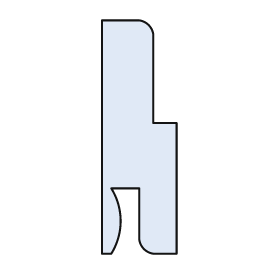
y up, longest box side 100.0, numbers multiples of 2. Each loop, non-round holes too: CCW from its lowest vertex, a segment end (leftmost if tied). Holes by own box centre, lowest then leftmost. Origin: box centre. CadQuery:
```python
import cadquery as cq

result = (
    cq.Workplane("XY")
    .moveTo(-16.0, -50.0)
    .lineTo(-12.0, -50.0)
    .threePointArc((-8.0, -36.0), (-12.0, -22.0))
    .lineTo(0.0, -22.0)
    .lineTo(0.0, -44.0)
    .threePointArc((2.0, -48.0), (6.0, -50.0))
    .lineTo(16.0, -50.0)
    .lineTo(16.0, 6.0)
    .lineTo(6.0, 6.0)
    .lineTo(6.0, 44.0)
    .threePointArc((4.0, 48.0), (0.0, 50.0))
    .lineTo(-16.0, 50.0)
    .close()
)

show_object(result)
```